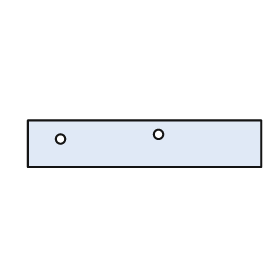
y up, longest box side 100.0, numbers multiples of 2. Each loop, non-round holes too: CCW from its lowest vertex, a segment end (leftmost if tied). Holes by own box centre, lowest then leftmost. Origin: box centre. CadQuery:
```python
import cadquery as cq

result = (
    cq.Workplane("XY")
    .moveTo(-50.0, -10.0)
    .lineTo(50.0, -10.0)
    .lineTo(50.0, 10.0)
    .lineTo(-50.0, 10.0)
    .close()
    .moveTo(-36.0, 2.0)
    .circle(2.0)
    .moveTo(6.0, 4.0)
    .circle(2.0)
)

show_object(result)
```